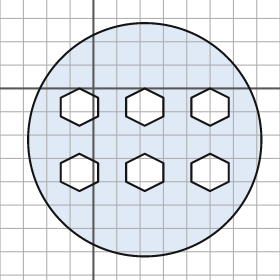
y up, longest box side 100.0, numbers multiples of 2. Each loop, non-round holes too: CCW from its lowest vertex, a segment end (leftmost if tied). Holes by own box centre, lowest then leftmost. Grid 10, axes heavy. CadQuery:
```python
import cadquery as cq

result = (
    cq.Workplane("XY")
    .moveTo(22.0, -22.0)
    .circle(50.0)
    .moveTo(-6.0, -44.0)
    .lineTo(2.0, -40.0)
    .lineTo(2.0, -32.0)
    .lineTo(-6.0, -28.0)
    .lineTo(-14.0, -32.0)
    .lineTo(-14.0, -40.0)
    .close()
    .moveTo(22.0, -44.0)
    .lineTo(30.0, -40.0)
    .lineTo(30.0, -32.0)
    .lineTo(22.0, -28.0)
    .lineTo(14.0, -32.0)
    .lineTo(14.0, -40.0)
    .close()
    .moveTo(50.0, -44.0)
    .lineTo(58.0, -40.0)
    .lineTo(58.0, -32.0)
    .lineTo(50.0, -28.0)
    .lineTo(42.0, -32.0)
    .lineTo(42.0, -40.0)
    .close()
    .moveTo(-6.0, -16.0)
    .lineTo(2.0, -12.0)
    .lineTo(2.0, -4.0)
    .lineTo(-6.0, 0.0)
    .lineTo(-14.0, -4.0)
    .lineTo(-14.0, -12.0)
    .close()
    .moveTo(22.0, -16.0)
    .lineTo(30.0, -12.0)
    .lineTo(30.0, -4.0)
    .lineTo(22.0, 0.0)
    .lineTo(14.0, -4.0)
    .lineTo(14.0, -12.0)
    .close()
    .moveTo(50.0, -16.0)
    .lineTo(58.0, -12.0)
    .lineTo(58.0, -4.0)
    .lineTo(50.0, 0.0)
    .lineTo(42.0, -4.0)
    .lineTo(42.0, -12.0)
    .close()
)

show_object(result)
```